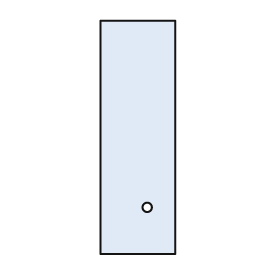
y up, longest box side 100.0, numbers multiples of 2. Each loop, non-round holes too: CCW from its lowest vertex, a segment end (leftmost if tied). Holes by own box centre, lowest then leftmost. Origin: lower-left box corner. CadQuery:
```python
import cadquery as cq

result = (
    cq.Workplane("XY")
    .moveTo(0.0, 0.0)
    .lineTo(32.0, 0.0)
    .lineTo(32.0, 100.0)
    .lineTo(0.0, 100.0)
    .close()
    .moveTo(20.0, 20.0)
    .circle(2.0)
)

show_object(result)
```